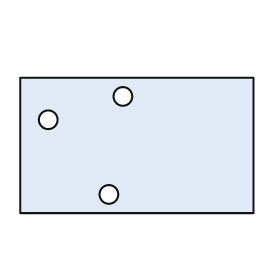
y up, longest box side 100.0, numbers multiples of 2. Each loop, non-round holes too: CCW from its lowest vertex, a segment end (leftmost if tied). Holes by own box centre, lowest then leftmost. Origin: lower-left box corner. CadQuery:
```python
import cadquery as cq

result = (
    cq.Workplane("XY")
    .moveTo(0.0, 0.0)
    .lineTo(100.0, 0.0)
    .lineTo(100.0, 58.0)
    .lineTo(0.0, 58.0)
    .close()
    .moveTo(38.0, 8.0)
    .circle(4.0)
    .moveTo(12.0, 40.0)
    .circle(4.0)
    .moveTo(44.0, 50.0)
    .circle(4.0)
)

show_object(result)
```